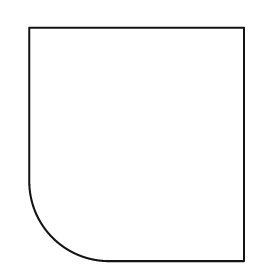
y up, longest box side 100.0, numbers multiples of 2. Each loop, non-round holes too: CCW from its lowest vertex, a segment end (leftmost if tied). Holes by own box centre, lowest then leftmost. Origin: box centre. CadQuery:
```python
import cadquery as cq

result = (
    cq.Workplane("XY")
    .moveTo(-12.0, -50.0)
    .lineTo(46.0, -50.0)
    .lineTo(46.0, 50.0)
    .lineTo(-46.0, 50.0)
    .lineTo(-46.0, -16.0)
    .threePointArc((-36.0, -40.0), (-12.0, -50.0))
    .close()
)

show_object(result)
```